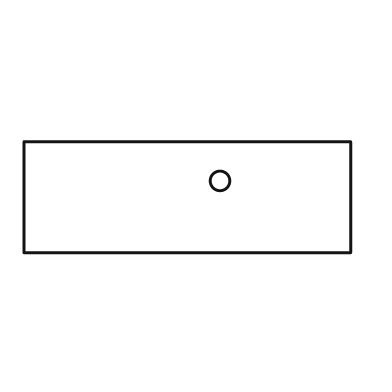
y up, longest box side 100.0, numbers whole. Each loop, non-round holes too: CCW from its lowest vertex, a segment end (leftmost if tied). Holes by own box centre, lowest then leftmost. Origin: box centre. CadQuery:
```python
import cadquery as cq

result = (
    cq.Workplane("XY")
    .moveTo(-50.0, -17.0)
    .lineTo(50.0, -17.0)
    .lineTo(50.0, 17.0)
    .lineTo(-50.0, 17.0)
    .close()
    .moveTo(10.0, 5.0)
    .circle(3.0)
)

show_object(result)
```